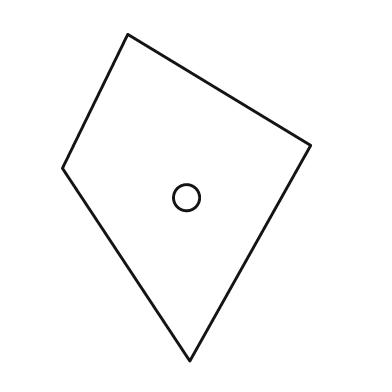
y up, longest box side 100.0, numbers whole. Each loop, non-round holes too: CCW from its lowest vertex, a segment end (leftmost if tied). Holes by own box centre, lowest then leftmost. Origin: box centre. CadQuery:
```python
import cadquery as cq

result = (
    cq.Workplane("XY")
    .moveTo(1.0, -50.0)
    .lineTo(38.0, 16.0)
    .lineTo(-18.0, 50.0)
    .lineTo(-38.0, 9.0)
    .close()
    .moveTo(0.0, 0.0)
    .circle(4.0)
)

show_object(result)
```